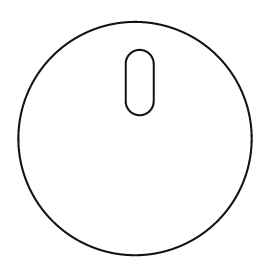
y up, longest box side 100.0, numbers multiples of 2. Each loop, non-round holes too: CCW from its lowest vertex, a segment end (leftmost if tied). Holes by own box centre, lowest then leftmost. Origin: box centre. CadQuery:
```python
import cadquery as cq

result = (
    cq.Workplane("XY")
    .moveTo(0.0, 0.0)
    .circle(50.0)
    .moveTo(-4.0, 16.0)
    .threePointArc((2.0, 10.0), (8.0, 16.0))
    .lineTo(8.0, 32.0)
    .threePointArc((2.0, 38.0), (-4.0, 32.0))
    .close()
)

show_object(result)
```